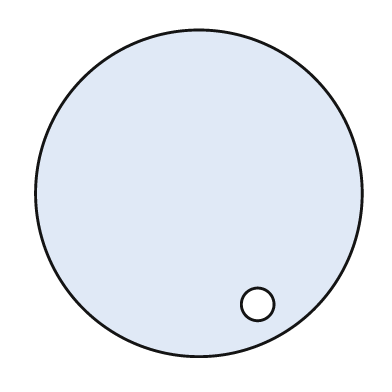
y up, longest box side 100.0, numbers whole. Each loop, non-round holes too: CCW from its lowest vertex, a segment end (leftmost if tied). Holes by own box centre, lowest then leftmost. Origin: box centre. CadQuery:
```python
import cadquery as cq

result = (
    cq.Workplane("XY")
    .moveTo(0.0, 0.0)
    .circle(50.0)
    .moveTo(18.0, -34.0)
    .circle(5.0)
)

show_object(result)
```